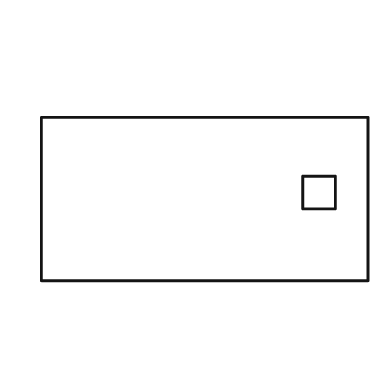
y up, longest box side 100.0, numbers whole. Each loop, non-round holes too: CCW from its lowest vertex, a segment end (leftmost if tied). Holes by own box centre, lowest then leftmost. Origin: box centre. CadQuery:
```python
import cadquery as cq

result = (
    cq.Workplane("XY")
    .moveTo(-50.0, -25.0)
    .lineTo(50.0, -25.0)
    .lineTo(50.0, 25.0)
    .lineTo(-50.0, 25.0)
    .close()
    .moveTo(30.0, -3.0)
    .lineTo(40.0, -3.0)
    .lineTo(40.0, 7.0)
    .lineTo(30.0, 7.0)
    .close()
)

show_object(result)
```